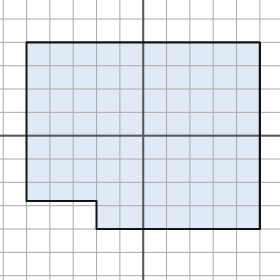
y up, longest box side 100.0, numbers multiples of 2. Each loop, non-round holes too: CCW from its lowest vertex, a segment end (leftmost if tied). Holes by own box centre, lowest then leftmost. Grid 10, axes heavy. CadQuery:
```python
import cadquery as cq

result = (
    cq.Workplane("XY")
    .moveTo(-20.0, -40.0)
    .lineTo(50.0, -40.0)
    .lineTo(50.0, 40.0)
    .lineTo(-50.0, 40.0)
    .lineTo(-50.0, -28.0)
    .lineTo(-20.0, -28.0)
    .close()
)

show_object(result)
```